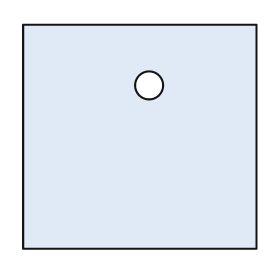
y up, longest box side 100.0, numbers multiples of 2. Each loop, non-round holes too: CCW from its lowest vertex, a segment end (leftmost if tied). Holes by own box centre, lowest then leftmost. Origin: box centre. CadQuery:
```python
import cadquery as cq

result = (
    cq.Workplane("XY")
    .moveTo(-50.0, -48.0)
    .lineTo(50.0, -48.0)
    .lineTo(50.0, 48.0)
    .lineTo(-50.0, 48.0)
    .close()
    .moveTo(4.0, 22.0)
    .circle(6.0)
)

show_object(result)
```